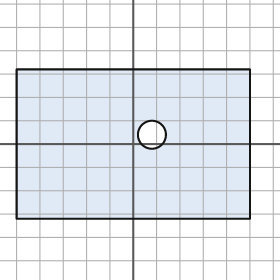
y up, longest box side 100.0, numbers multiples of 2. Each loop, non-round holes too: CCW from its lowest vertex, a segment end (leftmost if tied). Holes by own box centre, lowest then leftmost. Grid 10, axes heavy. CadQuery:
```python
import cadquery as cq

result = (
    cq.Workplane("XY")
    .moveTo(-50.0, -32.0)
    .lineTo(50.0, -32.0)
    .lineTo(50.0, 32.0)
    .lineTo(-50.0, 32.0)
    .close()
    .moveTo(8.0, 4.0)
    .circle(6.0)
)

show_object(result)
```